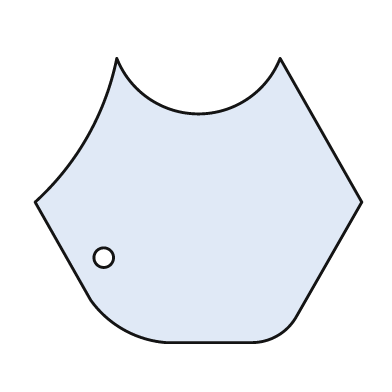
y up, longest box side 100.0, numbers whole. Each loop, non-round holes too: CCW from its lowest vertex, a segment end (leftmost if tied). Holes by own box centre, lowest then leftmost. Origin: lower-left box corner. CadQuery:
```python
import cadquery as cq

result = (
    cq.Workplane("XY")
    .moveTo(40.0, 0.0)
    .lineTo(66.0, 0.0)
    .threePointArc((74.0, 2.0), (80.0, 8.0))
    .lineTo(100.0, 43.0)
    .lineTo(75.0, 87.0)
    .threePointArc((50.0, 70.0), (25.0, 87.0))
    .threePointArc((16.0, 63.0), (0.0, 43.0))
    .lineTo(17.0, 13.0)
    .threePointArc((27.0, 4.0), (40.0, 0.0))
    .close()
    .moveTo(21.0, 26.0)
    .circle(3.0)
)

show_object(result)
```